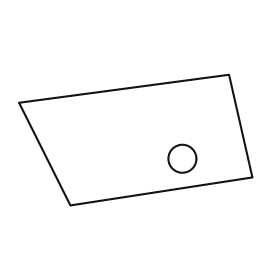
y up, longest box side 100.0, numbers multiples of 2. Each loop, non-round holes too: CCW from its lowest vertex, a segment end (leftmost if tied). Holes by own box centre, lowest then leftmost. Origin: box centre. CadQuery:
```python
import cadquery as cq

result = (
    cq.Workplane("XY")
    .moveTo(-28.0, -28.0)
    .lineTo(50.0, -16.0)
    .lineTo(40.0, 28.0)
    .lineTo(-50.0, 16.0)
    .close()
    .moveTo(20.0, -8.0)
    .circle(6.0)
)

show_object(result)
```